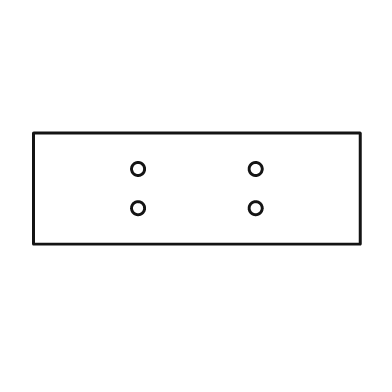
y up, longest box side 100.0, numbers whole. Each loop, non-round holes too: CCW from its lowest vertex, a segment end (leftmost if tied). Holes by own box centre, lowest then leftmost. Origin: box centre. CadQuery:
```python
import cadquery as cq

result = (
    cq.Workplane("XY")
    .moveTo(-50.0, -17.0)
    .lineTo(50.0, -17.0)
    .lineTo(50.0, 17.0)
    .lineTo(-50.0, 17.0)
    .close()
    .moveTo(-18.0, -6.0)
    .circle(2.0)
    .moveTo(18.0, -6.0)
    .circle(2.0)
    .moveTo(-18.0, 6.0)
    .circle(2.0)
    .moveTo(18.0, 6.0)
    .circle(2.0)
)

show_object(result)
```